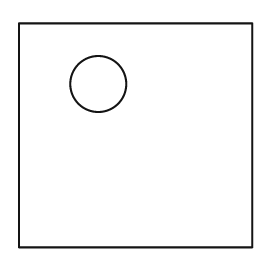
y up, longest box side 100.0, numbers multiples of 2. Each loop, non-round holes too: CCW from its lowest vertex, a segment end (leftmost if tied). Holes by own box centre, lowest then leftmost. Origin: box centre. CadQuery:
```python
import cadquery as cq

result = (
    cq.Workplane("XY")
    .moveTo(-50.0, -48.0)
    .lineTo(50.0, -48.0)
    .lineTo(50.0, 48.0)
    .lineTo(-50.0, 48.0)
    .close()
    .moveTo(-16.0, 22.0)
    .circle(12.0)
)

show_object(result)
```